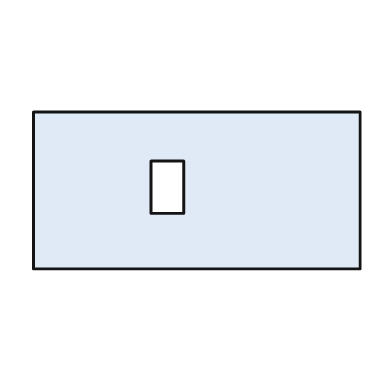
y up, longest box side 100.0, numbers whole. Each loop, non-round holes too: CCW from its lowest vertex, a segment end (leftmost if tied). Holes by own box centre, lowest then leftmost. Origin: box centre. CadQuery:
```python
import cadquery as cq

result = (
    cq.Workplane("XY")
    .moveTo(-50.0, -24.0)
    .lineTo(50.0, -24.0)
    .lineTo(50.0, 24.0)
    .lineTo(-50.0, 24.0)
    .close()
    .moveTo(-14.0, -7.0)
    .lineTo(-4.0, -7.0)
    .lineTo(-4.0, 9.0)
    .lineTo(-14.0, 9.0)
    .close()
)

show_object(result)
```